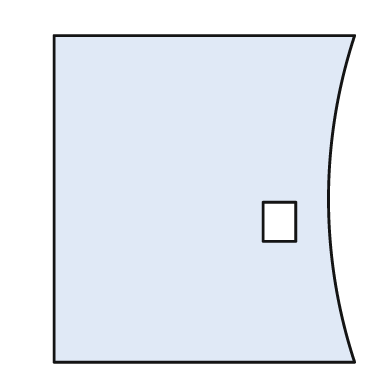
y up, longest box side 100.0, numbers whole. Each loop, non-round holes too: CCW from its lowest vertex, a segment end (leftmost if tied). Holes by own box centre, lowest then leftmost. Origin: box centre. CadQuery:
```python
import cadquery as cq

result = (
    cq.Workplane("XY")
    .moveTo(-46.0, -50.0)
    .lineTo(46.0, -50.0)
    .threePointArc((38.0, 0.0), (46.0, 50.0))
    .lineTo(-46.0, 50.0)
    .close()
    .moveTo(18.0, -13.0)
    .lineTo(28.0, -13.0)
    .lineTo(28.0, -1.0)
    .lineTo(18.0, -1.0)
    .close()
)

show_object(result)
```